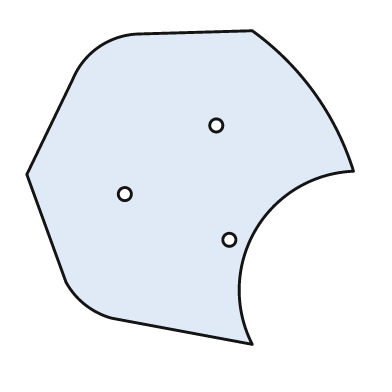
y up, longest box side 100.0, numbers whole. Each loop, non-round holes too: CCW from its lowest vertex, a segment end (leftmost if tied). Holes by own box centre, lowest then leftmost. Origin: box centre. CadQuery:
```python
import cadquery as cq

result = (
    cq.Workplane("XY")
    .moveTo(19.0, -48.0)
    .threePointArc((20.0, -13.0), (50.0, 5.0))
    .threePointArc((38.0, 29.0), (19.0, 48.0))
    .lineTo(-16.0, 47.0)
    .threePointArc((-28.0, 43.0), (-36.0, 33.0))
    .lineTo(-50.0, 4.0)
    .lineTo(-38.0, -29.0)
    .threePointArc((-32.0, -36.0), (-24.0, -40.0))
    .close()
    .moveTo(12.0, -16.0)
    .circle(2.0)
    .moveTo(-20.0, -2.0)
    .circle(2.0)
    .moveTo(8.0, 19.0)
    .circle(2.0)
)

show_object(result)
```